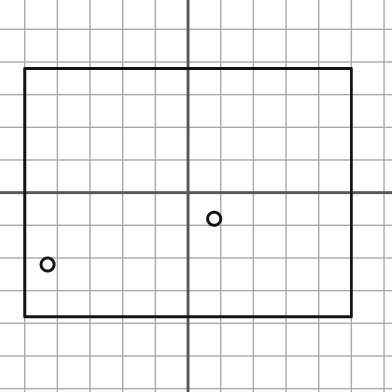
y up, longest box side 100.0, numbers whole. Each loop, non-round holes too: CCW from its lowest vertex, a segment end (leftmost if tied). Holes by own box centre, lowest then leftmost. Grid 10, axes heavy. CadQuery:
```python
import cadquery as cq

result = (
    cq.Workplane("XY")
    .moveTo(-50.0, -38.0)
    .lineTo(50.0, -38.0)
    .lineTo(50.0, 38.0)
    .lineTo(-50.0, 38.0)
    .close()
    .moveTo(-43.0, -22.0)
    .circle(2.0)
    .moveTo(8.0, -8.0)
    .circle(2.0)
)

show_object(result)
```